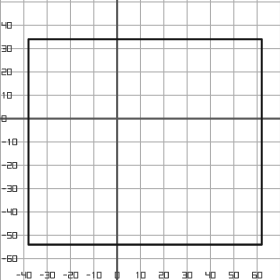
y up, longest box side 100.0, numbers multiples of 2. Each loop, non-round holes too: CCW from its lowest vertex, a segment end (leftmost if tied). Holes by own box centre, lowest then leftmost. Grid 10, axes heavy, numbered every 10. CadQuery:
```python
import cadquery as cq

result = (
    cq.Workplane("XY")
    .moveTo(-38.0, -54.0)
    .lineTo(62.0, -54.0)
    .lineTo(62.0, 34.0)
    .lineTo(-38.0, 34.0)
    .close()
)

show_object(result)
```